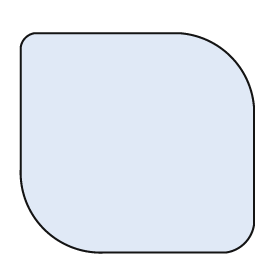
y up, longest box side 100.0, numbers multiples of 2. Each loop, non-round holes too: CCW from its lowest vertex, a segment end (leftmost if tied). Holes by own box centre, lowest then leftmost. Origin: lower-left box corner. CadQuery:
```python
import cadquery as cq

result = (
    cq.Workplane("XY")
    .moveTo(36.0, 0.0)
    .lineTo(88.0, 0.0)
    .threePointArc((96.0, 4.0), (100.0, 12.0))
    .lineTo(100.0, 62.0)
    .threePointArc((90.0, 84.0), (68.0, 94.0))
    .lineTo(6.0, 94.0)
    .threePointArc((2.0, 92.0), (0.0, 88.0))
    .lineTo(0.0, 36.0)
    .threePointArc((10.0, 10.0), (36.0, 0.0))
    .close()
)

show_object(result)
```